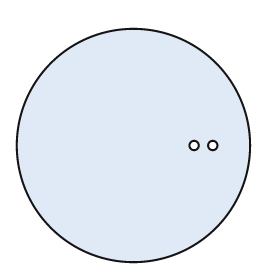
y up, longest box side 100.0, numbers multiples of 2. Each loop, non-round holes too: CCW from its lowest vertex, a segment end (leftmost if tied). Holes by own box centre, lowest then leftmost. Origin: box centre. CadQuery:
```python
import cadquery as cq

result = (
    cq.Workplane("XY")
    .moveTo(0.0, 0.0)
    .circle(50.0)
    .moveTo(26.0, 0.0)
    .circle(2.0)
    .moveTo(34.0, 0.0)
    .circle(2.0)
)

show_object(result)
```